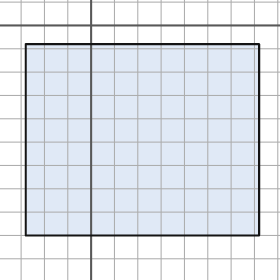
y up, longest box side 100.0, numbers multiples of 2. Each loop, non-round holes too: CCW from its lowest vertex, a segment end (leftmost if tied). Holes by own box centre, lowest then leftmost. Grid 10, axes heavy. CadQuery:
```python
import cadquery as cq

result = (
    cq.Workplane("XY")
    .moveTo(-28.0, -90.0)
    .lineTo(72.0, -90.0)
    .lineTo(72.0, -8.0)
    .lineTo(-28.0, -8.0)
    .close()
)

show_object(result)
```